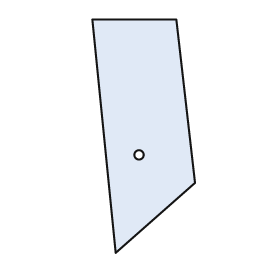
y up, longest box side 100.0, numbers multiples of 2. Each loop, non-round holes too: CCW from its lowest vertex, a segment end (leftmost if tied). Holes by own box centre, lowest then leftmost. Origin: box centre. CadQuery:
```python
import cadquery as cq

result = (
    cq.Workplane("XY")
    .moveTo(-12.0, -50.0)
    .lineTo(22.0, -20.0)
    .lineTo(14.0, 50.0)
    .lineTo(-22.0, 50.0)
    .close()
    .moveTo(-2.0, -8.0)
    .circle(2.0)
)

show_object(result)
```